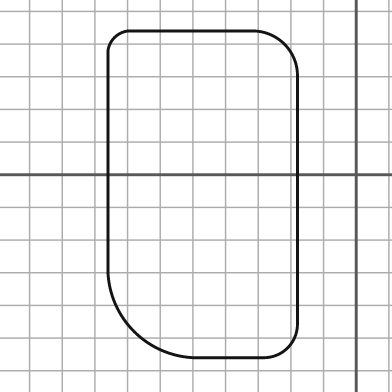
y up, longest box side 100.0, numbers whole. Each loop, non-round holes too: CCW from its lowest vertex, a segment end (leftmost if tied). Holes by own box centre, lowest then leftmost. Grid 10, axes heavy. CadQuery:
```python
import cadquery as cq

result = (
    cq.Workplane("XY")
    .moveTo(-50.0, -56.0)
    .lineTo(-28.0, -56.0)
    .threePointArc((-21.0, -53.0), (-18.0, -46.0))
    .lineTo(-18.0, 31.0)
    .threePointArc((-22.0, 40.0), (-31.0, 44.0))
    .lineTo(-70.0, 44.0)
    .threePointArc((-74.0, 42.0), (-76.0, 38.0))
    .lineTo(-76.0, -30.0)
    .threePointArc((-68.0, -48.0), (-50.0, -56.0))
    .close()
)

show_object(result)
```